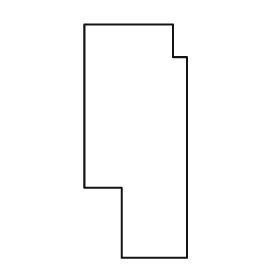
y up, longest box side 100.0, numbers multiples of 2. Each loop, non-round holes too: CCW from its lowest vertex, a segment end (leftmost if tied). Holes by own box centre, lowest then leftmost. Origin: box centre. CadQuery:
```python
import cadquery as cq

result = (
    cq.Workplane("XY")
    .moveTo(-6.0, -50.0)
    .lineTo(22.0, -50.0)
    .lineTo(22.0, 36.0)
    .lineTo(16.0, 36.0)
    .lineTo(16.0, 50.0)
    .lineTo(-22.0, 50.0)
    .lineTo(-22.0, -20.0)
    .lineTo(-6.0, -20.0)
    .close()
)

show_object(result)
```